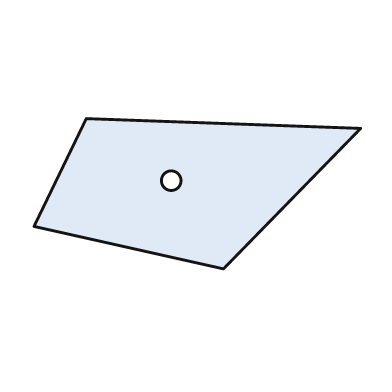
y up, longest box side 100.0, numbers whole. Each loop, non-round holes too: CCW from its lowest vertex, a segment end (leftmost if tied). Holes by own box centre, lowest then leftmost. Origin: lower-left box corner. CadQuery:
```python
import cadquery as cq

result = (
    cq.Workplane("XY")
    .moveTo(58.0, 0.0)
    .lineTo(100.0, 43.0)
    .lineTo(16.0, 46.0)
    .lineTo(0.0, 13.0)
    .close()
    .moveTo(42.0, 27.0)
    .circle(3.0)
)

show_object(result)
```